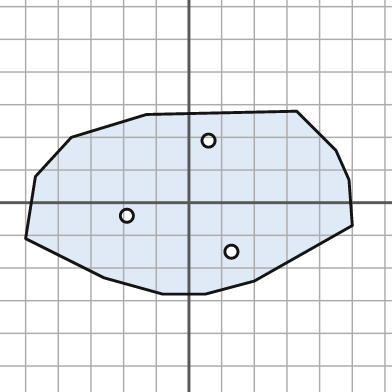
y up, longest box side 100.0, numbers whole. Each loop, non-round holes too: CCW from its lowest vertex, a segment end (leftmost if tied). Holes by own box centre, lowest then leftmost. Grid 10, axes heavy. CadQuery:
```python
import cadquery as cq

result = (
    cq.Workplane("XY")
    .moveTo(-8.0, -28.0)
    .lineTo(5.0, -28.0)
    .lineTo(20.0, -24.0)
    .lineTo(50.0, -7.0)
    .lineTo(49.0, 7.0)
    .lineTo(45.0, 16.0)
    .lineTo(33.0, 28.0)
    .lineTo(-13.0, 27.0)
    .lineTo(-36.0, 20.0)
    .lineTo(-47.0, 8.0)
    .lineTo(-50.0, -11.0)
    .lineTo(-26.0, -23.0)
    .close()
    .moveTo(13.0, -15.0)
    .circle(2.0)
    .moveTo(-19.0, -4.0)
    .circle(2.0)
    .moveTo(6.0, 19.0)
    .circle(2.0)
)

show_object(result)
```